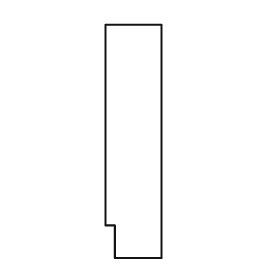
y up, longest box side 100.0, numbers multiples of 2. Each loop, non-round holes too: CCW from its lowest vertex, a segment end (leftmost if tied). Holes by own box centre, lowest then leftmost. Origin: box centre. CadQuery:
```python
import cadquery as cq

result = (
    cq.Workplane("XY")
    .moveTo(-8.0, -50.0)
    .lineTo(12.0, -50.0)
    .lineTo(12.0, 50.0)
    .lineTo(-12.0, 50.0)
    .lineTo(-12.0, -36.0)
    .lineTo(-8.0, -36.0)
    .close()
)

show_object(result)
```